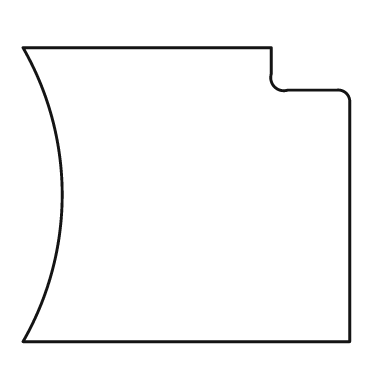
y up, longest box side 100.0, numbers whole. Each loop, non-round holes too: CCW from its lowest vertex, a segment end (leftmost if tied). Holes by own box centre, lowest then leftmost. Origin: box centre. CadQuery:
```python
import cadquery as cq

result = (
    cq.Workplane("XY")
    .moveTo(-50.0, -45.0)
    .lineTo(50.0, -45.0)
    .lineTo(50.0, 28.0)
    .threePointArc((49.0, 31.0), (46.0, 32.0))
    .lineTo(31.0, 32.0)
    .threePointArc((27.0, 33.0), (26.0, 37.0))
    .lineTo(26.0, 45.0)
    .lineTo(-50.0, 45.0)
    .threePointArc((-38.0, 0.0), (-50.0, -45.0))
    .close()
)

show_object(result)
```